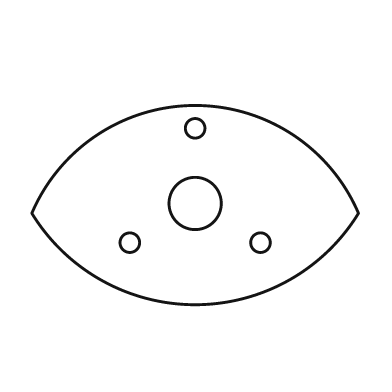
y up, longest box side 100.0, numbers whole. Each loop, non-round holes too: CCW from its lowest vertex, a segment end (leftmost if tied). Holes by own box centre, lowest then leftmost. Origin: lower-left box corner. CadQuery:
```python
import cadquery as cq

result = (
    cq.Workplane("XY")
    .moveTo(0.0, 28.0)
    .threePointArc((50.0, 0.0), (100.0, 28.0))
    .threePointArc((50.0, 61.0), (0.0, 28.0))
    .close()
    .moveTo(30.0, 19.0)
    .circle(3.0)
    .moveTo(70.0, 19.0)
    .circle(3.0)
    .moveTo(50.0, 31.0)
    .circle(8.0)
    .moveTo(50.0, 54.0)
    .circle(3.0)
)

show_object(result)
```